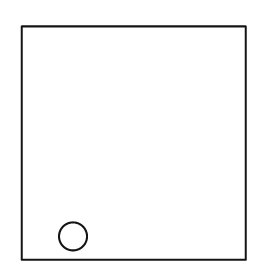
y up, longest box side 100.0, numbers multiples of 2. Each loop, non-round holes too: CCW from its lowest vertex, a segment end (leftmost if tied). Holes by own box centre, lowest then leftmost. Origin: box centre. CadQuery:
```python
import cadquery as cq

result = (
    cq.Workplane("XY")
    .moveTo(-48.0, -50.0)
    .lineTo(48.0, -50.0)
    .lineTo(48.0, 50.0)
    .lineTo(-48.0, 50.0)
    .close()
    .moveTo(-26.0, -40.0)
    .circle(6.0)
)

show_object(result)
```